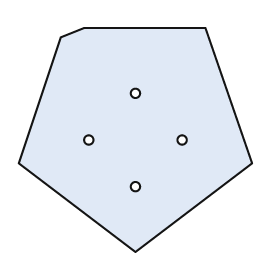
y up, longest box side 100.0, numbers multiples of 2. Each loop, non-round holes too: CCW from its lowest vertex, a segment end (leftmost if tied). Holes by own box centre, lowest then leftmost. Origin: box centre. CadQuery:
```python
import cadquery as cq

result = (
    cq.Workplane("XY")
    .moveTo(0.0, -48.0)
    .lineTo(50.0, -10.0)
    .lineTo(30.0, 48.0)
    .lineTo(-22.0, 48.0)
    .lineTo(-32.0, 44.0)
    .lineTo(-50.0, -10.0)
    .close()
    .moveTo(0.0, -20.0)
    .circle(2.0)
    .moveTo(-20.0, 0.0)
    .circle(2.0)
    .moveTo(20.0, 0.0)
    .circle(2.0)
    .moveTo(0.0, 20.0)
    .circle(2.0)
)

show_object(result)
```